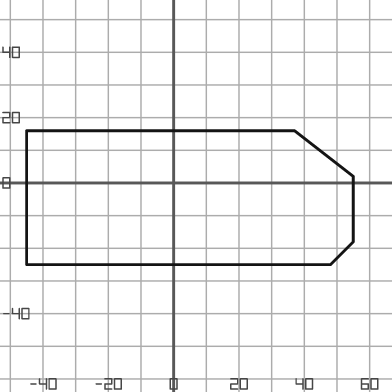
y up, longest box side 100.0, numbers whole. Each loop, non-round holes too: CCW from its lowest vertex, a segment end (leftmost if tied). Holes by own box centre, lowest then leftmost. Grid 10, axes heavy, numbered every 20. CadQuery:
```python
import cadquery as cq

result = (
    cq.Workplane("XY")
    .moveTo(-45.0, -25.0)
    .lineTo(48.0, -25.0)
    .lineTo(55.0, -18.0)
    .lineTo(55.0, 2.0)
    .lineTo(37.0, 16.0)
    .lineTo(-45.0, 16.0)
    .close()
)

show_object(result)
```